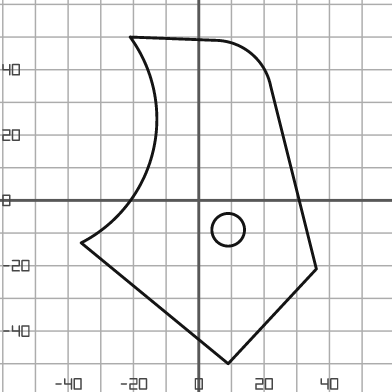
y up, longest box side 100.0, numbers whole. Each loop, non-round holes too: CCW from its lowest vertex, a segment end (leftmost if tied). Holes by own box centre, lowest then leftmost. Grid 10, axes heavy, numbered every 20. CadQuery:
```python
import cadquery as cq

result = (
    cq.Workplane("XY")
    .moveTo(9.0, -50.0)
    .lineTo(36.0, -21.0)
    .lineTo(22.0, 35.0)
    .threePointArc((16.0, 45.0), (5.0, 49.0))
    .lineTo(-21.0, 50.0)
    .threePointArc((-14.0, 15.0), (-36.0, -13.0))
    .close()
    .moveTo(9.0, -9.0)
    .circle(5.0)
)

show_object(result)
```